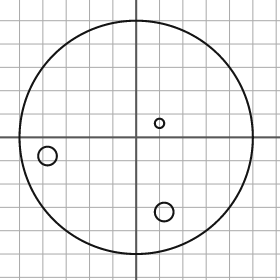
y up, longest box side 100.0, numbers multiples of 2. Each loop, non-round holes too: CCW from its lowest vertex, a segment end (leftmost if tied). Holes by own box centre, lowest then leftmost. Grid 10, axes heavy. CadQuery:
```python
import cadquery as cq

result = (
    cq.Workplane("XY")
    .moveTo(0.0, 0.0)
    .circle(50.0)
    .moveTo(12.0, -32.0)
    .circle(4.0)
    .moveTo(-38.0, -8.0)
    .circle(4.0)
    .moveTo(10.0, 6.0)
    .circle(2.0)
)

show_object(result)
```